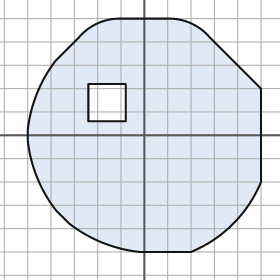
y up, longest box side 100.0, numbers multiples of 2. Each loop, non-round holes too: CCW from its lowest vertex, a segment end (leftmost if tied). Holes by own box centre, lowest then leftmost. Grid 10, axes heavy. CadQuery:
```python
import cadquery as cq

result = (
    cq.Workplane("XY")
    .moveTo(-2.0, -50.0)
    .lineTo(20.0, -50.0)
    .threePointArc((38.0, -38.0), (50.0, -20.0))
    .lineTo(50.0, 20.0)
    .lineTo(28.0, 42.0)
    .threePointArc((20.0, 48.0), (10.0, 50.0))
    .lineTo(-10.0, 50.0)
    .threePointArc((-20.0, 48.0), (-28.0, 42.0))
    .lineTo(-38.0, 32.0)
    .threePointArc((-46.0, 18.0), (-50.0, 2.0))
    .lineTo(-50.0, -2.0)
    .threePointArc((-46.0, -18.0), (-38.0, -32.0))
    .lineTo(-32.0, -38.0)
    .threePointArc((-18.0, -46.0), (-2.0, -50.0))
    .close()
    .moveTo(-24.0, 6.0)
    .lineTo(-8.0, 6.0)
    .lineTo(-8.0, 22.0)
    .lineTo(-24.0, 22.0)
    .close()
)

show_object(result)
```